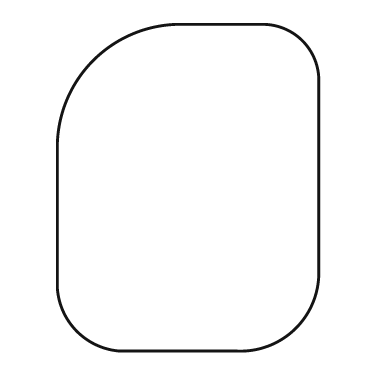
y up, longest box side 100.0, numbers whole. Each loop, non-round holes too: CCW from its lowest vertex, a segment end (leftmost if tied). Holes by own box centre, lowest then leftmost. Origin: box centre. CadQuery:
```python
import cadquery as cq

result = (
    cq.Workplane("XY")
    .moveTo(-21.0, -50.0)
    .lineTo(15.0, -50.0)
    .threePointArc((33.0, -43.0), (40.0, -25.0))
    .lineTo(40.0, 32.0)
    .threePointArc((35.0, 45.0), (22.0, 50.0))
    .lineTo(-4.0, 50.0)
    .threePointArc((-29.0, 39.0), (-40.0, 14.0))
    .lineTo(-40.0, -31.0)
    .threePointArc((-34.0, -44.0), (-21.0, -50.0))
    .close()
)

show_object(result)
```